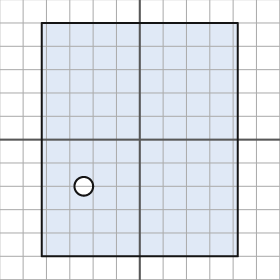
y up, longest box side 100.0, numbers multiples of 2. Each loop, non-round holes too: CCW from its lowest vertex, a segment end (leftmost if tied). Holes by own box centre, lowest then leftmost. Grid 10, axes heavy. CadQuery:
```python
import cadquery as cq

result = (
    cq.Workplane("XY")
    .moveTo(-42.0, -50.0)
    .lineTo(42.0, -50.0)
    .lineTo(42.0, 50.0)
    .lineTo(-42.0, 50.0)
    .close()
    .moveTo(-24.0, -20.0)
    .circle(4.0)
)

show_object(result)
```